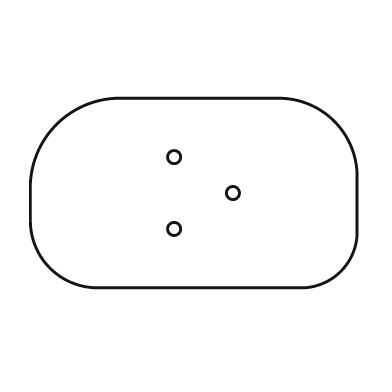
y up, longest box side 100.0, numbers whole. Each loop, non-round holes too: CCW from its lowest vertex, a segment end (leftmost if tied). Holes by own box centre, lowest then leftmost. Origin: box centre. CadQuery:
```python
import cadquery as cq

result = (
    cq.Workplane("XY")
    .moveTo(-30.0, -29.0)
    .lineTo(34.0, -29.0)
    .threePointArc((45.0, -24.0), (50.0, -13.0))
    .lineTo(50.0, 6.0)
    .threePointArc((43.0, 22.0), (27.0, 29.0))
    .lineTo(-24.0, 29.0)
    .threePointArc((-42.0, 21.0), (-50.0, 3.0))
    .lineTo(-50.0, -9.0)
    .threePointArc((-44.0, -23.0), (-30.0, -29.0))
    .close()
    .moveTo(-6.0, -11.0)
    .circle(2.0)
    .moveTo(12.0, 0.0)
    .circle(2.0)
    .moveTo(-6.0, 11.0)
    .circle(2.0)
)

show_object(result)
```